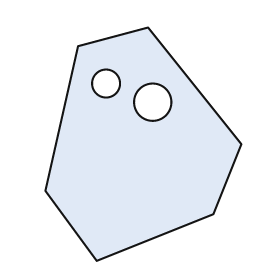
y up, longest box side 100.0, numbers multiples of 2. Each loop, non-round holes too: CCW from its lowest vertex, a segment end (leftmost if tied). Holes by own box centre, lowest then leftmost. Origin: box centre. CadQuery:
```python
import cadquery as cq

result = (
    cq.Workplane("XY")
    .moveTo(-20.0, -50.0)
    .lineTo(30.0, -30.0)
    .lineTo(42.0, 0.0)
    .lineTo(2.0, 50.0)
    .lineTo(-28.0, 42.0)
    .lineTo(-42.0, -20.0)
    .close()
    .moveTo(4.0, 18.0)
    .circle(8.0)
    .moveTo(-16.0, 26.0)
    .circle(6.0)
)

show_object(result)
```